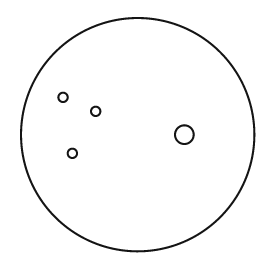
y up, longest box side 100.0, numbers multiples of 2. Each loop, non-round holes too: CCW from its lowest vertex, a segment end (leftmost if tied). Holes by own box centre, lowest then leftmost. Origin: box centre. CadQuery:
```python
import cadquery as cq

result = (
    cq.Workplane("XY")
    .moveTo(0.0, 0.0)
    .circle(50.0)
    .moveTo(-28.0, -8.0)
    .circle(2.0)
    .moveTo(20.0, 0.0)
    .circle(4.0)
    .moveTo(-18.0, 10.0)
    .circle(2.0)
    .moveTo(-32.0, 16.0)
    .circle(2.0)
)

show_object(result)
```